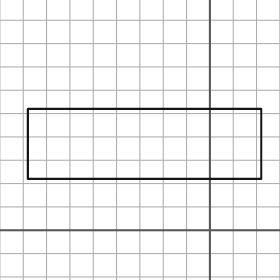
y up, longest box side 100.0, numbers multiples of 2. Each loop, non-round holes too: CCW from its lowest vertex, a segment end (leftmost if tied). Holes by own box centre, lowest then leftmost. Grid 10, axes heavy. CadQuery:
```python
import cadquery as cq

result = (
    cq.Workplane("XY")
    .moveTo(-78.0, 22.0)
    .lineTo(22.0, 22.0)
    .lineTo(22.0, 52.0)
    .lineTo(-78.0, 52.0)
    .close()
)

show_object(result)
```